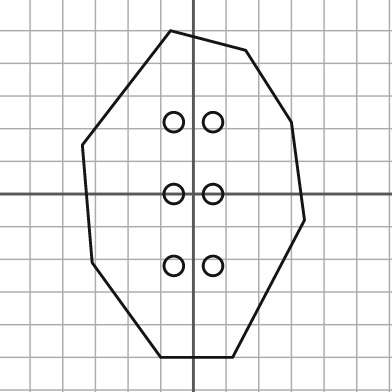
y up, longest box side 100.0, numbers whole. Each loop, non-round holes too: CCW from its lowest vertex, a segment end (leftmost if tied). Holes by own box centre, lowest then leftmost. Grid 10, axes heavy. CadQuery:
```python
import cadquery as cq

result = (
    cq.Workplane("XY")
    .moveTo(-10.0, -50.0)
    .lineTo(12.0, -50.0)
    .lineTo(34.0, -8.0)
    .lineTo(30.0, 22.0)
    .lineTo(16.0, 44.0)
    .lineTo(-7.0, 50.0)
    .lineTo(-34.0, 15.0)
    .lineTo(-31.0, -21.0)
    .close()
    .moveTo(-6.0, -22.0)
    .circle(3.0)
    .moveTo(6.0, -22.0)
    .circle(3.0)
    .moveTo(-6.0, 0.0)
    .circle(3.0)
    .moveTo(6.0, 0.0)
    .circle(3.0)
    .moveTo(-6.0, 22.0)
    .circle(3.0)
    .moveTo(6.0, 22.0)
    .circle(3.0)
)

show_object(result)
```